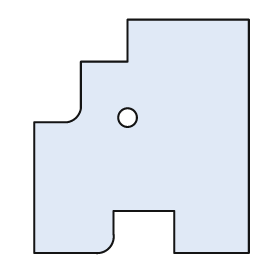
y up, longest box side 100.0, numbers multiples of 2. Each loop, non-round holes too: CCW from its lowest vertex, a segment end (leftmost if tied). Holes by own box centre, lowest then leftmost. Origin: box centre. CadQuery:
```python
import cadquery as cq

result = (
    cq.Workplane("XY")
    .moveTo(-46.0, -50.0)
    .lineTo(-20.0, -50.0)
    .threePointArc((-14.0, -48.0), (-12.0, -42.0))
    .lineTo(-12.0, -32.0)
    .lineTo(14.0, -32.0)
    .lineTo(14.0, -50.0)
    .lineTo(46.0, -50.0)
    .lineTo(46.0, 50.0)
    .lineTo(-6.0, 50.0)
    .lineTo(-6.0, 32.0)
    .lineTo(-26.0, 32.0)
    .lineTo(-26.0, 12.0)
    .threePointArc((-28.0, 8.0), (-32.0, 6.0))
    .lineTo(-46.0, 6.0)
    .close()
    .moveTo(-6.0, 8.0)
    .circle(4.0)
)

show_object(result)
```